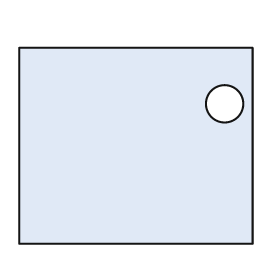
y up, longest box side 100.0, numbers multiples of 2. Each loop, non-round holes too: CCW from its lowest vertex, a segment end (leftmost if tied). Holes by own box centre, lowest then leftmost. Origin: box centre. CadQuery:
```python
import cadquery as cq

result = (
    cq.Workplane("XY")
    .moveTo(-50.0, -42.0)
    .lineTo(50.0, -42.0)
    .lineTo(50.0, 42.0)
    .lineTo(-50.0, 42.0)
    .close()
    .moveTo(38.0, 18.0)
    .circle(8.0)
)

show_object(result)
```